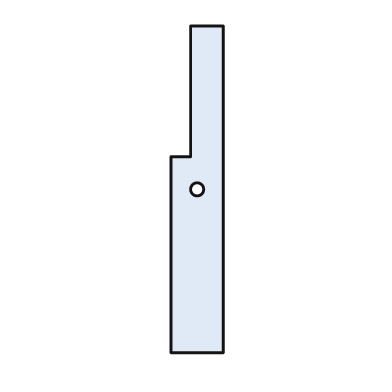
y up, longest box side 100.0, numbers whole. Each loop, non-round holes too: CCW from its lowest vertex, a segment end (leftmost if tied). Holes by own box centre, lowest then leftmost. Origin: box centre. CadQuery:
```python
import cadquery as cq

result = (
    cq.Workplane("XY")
    .moveTo(-8.0, -50.0)
    .lineTo(8.0, -50.0)
    .lineTo(8.0, 50.0)
    .lineTo(-2.0, 50.0)
    .lineTo(-2.0, 10.0)
    .lineTo(-8.0, 10.0)
    .close()
    .moveTo(0.0, 0.0)
    .circle(2.0)
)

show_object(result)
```